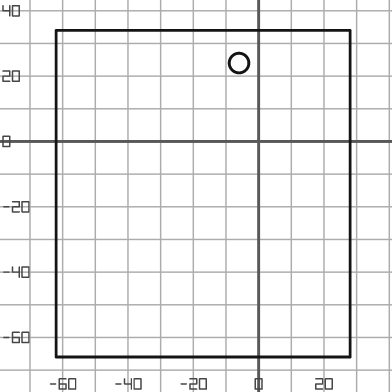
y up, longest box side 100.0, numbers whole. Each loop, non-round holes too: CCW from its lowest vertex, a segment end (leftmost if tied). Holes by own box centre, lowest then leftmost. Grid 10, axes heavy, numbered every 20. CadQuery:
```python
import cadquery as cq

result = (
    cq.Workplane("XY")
    .moveTo(-62.0, -66.0)
    .lineTo(28.0, -66.0)
    .lineTo(28.0, 34.0)
    .lineTo(-62.0, 34.0)
    .close()
    .moveTo(-6.0, 24.0)
    .circle(3.0)
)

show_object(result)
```